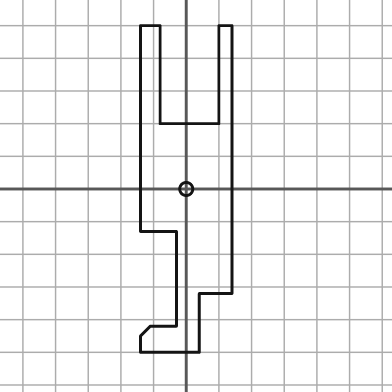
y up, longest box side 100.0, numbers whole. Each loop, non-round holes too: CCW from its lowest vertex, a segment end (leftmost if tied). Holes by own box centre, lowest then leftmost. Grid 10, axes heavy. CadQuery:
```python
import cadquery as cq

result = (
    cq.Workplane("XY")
    .moveTo(-14.0, -50.0)
    .lineTo(4.0, -50.0)
    .lineTo(4.0, -32.0)
    .lineTo(14.0, -32.0)
    .lineTo(14.0, 50.0)
    .lineTo(10.0, 50.0)
    .lineTo(10.0, 20.0)
    .lineTo(-8.0, 20.0)
    .lineTo(-8.0, 50.0)
    .lineTo(-14.0, 50.0)
    .lineTo(-14.0, -13.0)
    .lineTo(-3.0, -13.0)
    .lineTo(-3.0, -42.0)
    .lineTo(-11.0, -42.0)
    .lineTo(-14.0, -45.0)
    .close()
    .moveTo(0.0, 0.0)
    .circle(2.0)
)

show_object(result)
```